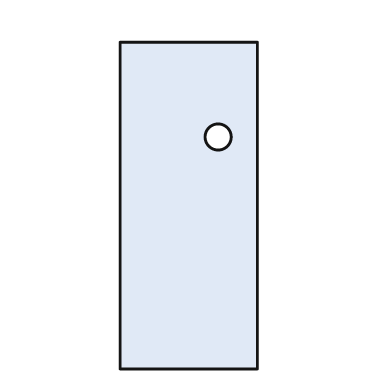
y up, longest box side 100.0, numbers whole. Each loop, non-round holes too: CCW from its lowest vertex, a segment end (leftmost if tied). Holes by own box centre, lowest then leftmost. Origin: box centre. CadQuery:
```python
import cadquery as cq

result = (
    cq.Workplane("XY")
    .moveTo(-21.0, -50.0)
    .lineTo(21.0, -50.0)
    .lineTo(21.0, 50.0)
    .lineTo(-21.0, 50.0)
    .close()
    .moveTo(9.0, 21.0)
    .circle(4.0)
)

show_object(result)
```